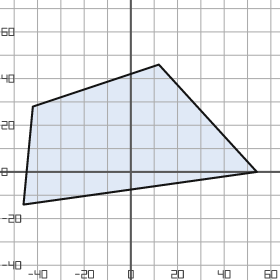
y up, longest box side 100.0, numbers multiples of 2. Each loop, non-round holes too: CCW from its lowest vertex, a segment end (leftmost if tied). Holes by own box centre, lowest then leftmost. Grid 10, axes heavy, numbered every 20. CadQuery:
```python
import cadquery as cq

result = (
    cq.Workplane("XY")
    .moveTo(-46.0, -14.0)
    .lineTo(54.0, 0.0)
    .lineTo(12.0, 46.0)
    .lineTo(-42.0, 28.0)
    .close()
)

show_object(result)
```